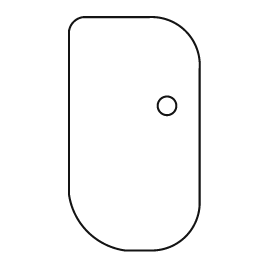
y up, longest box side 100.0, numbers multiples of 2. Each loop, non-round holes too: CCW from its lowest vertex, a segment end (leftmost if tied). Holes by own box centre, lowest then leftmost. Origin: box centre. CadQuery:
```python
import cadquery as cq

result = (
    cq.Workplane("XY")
    .moveTo(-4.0, -50.0)
    .lineTo(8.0, -50.0)
    .threePointArc((22.0, -44.0), (28.0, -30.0))
    .lineTo(28.0, 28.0)
    .threePointArc((22.0, 44.0), (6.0, 50.0))
    .lineTo(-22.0, 50.0)
    .threePointArc((-26.0, 48.0), (-28.0, 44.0))
    .lineTo(-28.0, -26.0)
    .threePointArc((-20.0, -42.0), (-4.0, -50.0))
    .close()
    .moveTo(14.0, 12.0)
    .circle(4.0)
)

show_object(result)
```